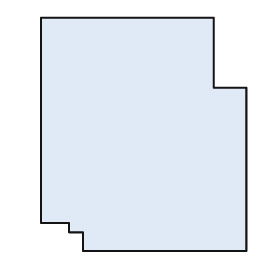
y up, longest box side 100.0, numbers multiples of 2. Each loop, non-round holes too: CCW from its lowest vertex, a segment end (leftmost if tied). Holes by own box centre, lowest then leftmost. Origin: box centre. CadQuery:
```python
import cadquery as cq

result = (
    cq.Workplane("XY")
    .moveTo(-26.0, -50.0)
    .lineTo(44.0, -50.0)
    .lineTo(44.0, 20.0)
    .lineTo(30.0, 20.0)
    .lineTo(30.0, 50.0)
    .lineTo(-44.0, 50.0)
    .lineTo(-44.0, -38.0)
    .lineTo(-32.0, -38.0)
    .lineTo(-32.0, -42.0)
    .lineTo(-26.0, -42.0)
    .close()
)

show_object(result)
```